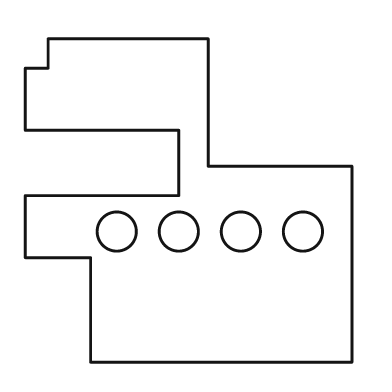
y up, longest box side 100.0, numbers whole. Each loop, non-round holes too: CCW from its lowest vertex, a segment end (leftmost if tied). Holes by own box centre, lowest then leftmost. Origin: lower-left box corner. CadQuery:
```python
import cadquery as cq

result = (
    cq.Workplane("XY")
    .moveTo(20.0, 0.0)
    .lineTo(100.0, 0.0)
    .lineTo(100.0, 60.0)
    .lineTo(56.0, 60.0)
    .lineTo(56.0, 99.0)
    .lineTo(7.0, 99.0)
    .lineTo(7.0, 90.0)
    .lineTo(0.0, 90.0)
    .lineTo(0.0, 71.0)
    .lineTo(47.0, 71.0)
    .lineTo(47.0, 51.0)
    .lineTo(0.0, 51.0)
    .lineTo(0.0, 32.0)
    .lineTo(20.0, 32.0)
    .close()
    .moveTo(28.0, 40.0)
    .circle(6.0)
    .moveTo(47.0, 40.0)
    .circle(6.0)
    .moveTo(66.0, 40.0)
    .circle(6.0)
    .moveTo(85.0, 40.0)
    .circle(6.0)
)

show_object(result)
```